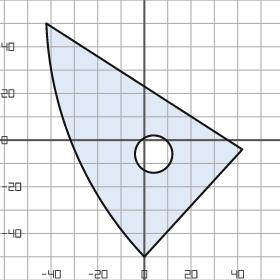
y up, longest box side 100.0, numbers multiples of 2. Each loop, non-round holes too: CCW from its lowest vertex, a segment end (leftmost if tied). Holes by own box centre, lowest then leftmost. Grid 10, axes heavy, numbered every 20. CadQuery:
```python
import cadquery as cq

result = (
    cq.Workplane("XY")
    .moveTo(0.0, -50.0)
    .lineTo(42.0, -4.0)
    .lineTo(-42.0, 50.0)
    .threePointArc((-30.0, -4.0), (0.0, -50.0))
    .close()
    .moveTo(4.0, -6.0)
    .circle(8.0)
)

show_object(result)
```